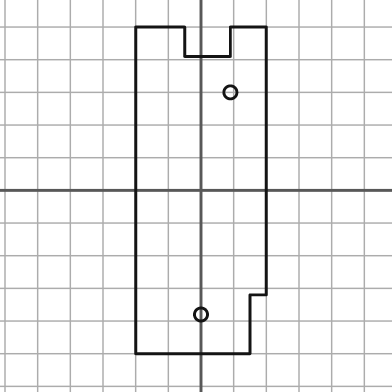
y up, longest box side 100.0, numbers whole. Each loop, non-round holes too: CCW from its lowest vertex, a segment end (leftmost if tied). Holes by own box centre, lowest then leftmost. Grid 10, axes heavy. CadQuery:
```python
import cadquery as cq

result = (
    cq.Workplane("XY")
    .moveTo(-20.0, -50.0)
    .lineTo(15.0, -50.0)
    .lineTo(15.0, -32.0)
    .lineTo(20.0, -32.0)
    .lineTo(20.0, 50.0)
    .lineTo(9.0, 50.0)
    .lineTo(9.0, 41.0)
    .lineTo(-5.0, 41.0)
    .lineTo(-5.0, 50.0)
    .lineTo(-20.0, 50.0)
    .close()
    .moveTo(0.0, -38.0)
    .circle(2.0)
    .moveTo(9.0, 30.0)
    .circle(2.0)
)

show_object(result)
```